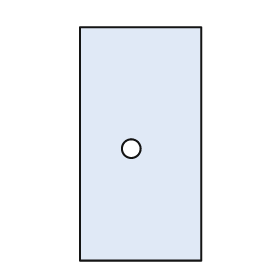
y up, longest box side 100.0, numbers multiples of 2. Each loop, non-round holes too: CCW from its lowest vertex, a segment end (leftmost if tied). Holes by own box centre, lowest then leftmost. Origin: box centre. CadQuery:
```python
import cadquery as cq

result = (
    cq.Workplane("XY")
    .moveTo(-26.0, -50.0)
    .lineTo(26.0, -50.0)
    .lineTo(26.0, 50.0)
    .lineTo(-26.0, 50.0)
    .close()
    .moveTo(-4.0, -2.0)
    .circle(4.0)
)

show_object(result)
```